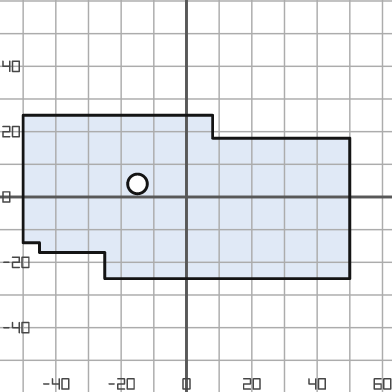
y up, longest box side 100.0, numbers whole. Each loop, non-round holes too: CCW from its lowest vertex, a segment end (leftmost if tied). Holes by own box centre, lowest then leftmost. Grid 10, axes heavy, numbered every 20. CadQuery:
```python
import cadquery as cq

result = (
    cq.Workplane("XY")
    .moveTo(-25.0, -25.0)
    .lineTo(50.0, -25.0)
    .lineTo(50.0, 18.0)
    .lineTo(8.0, 18.0)
    .lineTo(8.0, 25.0)
    .lineTo(-50.0, 25.0)
    .lineTo(-50.0, -14.0)
    .lineTo(-45.0, -14.0)
    .lineTo(-45.0, -17.0)
    .lineTo(-25.0, -17.0)
    .close()
    .moveTo(-15.0, 4.0)
    .circle(3.0)
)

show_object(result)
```